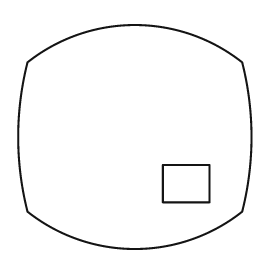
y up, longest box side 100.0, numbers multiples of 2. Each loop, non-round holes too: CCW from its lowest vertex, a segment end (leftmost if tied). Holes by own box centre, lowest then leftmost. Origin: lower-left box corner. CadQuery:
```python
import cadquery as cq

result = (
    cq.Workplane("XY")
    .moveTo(4.0, 16.0)
    .threePointArc((50.0, 0.0), (96.0, 16.0))
    .threePointArc((100.0, 48.0), (96.0, 80.0))
    .threePointArc((50.0, 96.0), (4.0, 80.0))
    .threePointArc((0.0, 48.0), (4.0, 16.0))
    .close()
    .moveTo(62.0, 20.0)
    .lineTo(82.0, 20.0)
    .lineTo(82.0, 36.0)
    .lineTo(62.0, 36.0)
    .close()
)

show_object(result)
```